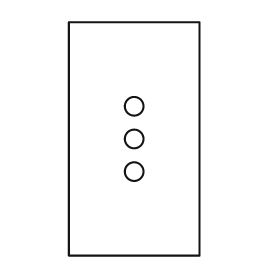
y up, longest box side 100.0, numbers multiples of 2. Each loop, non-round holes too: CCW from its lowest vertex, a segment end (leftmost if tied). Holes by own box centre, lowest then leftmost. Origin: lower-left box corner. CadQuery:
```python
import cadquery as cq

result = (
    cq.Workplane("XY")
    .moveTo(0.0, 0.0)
    .lineTo(56.0, 0.0)
    .lineTo(56.0, 100.0)
    .lineTo(0.0, 100.0)
    .close()
    .moveTo(28.0, 36.0)
    .circle(4.0)
    .moveTo(28.0, 50.0)
    .circle(4.0)
    .moveTo(28.0, 64.0)
    .circle(4.0)
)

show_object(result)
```